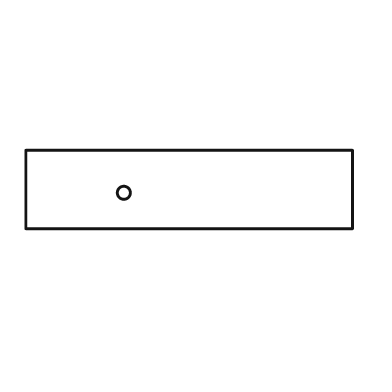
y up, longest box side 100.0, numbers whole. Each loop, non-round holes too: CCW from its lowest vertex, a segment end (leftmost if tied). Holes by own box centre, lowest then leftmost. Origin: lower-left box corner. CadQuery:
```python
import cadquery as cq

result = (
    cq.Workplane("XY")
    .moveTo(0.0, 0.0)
    .lineTo(100.0, 0.0)
    .lineTo(100.0, 24.0)
    .lineTo(0.0, 24.0)
    .close()
    .moveTo(30.0, 11.0)
    .circle(2.0)
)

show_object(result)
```